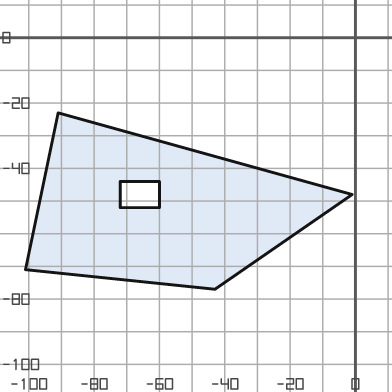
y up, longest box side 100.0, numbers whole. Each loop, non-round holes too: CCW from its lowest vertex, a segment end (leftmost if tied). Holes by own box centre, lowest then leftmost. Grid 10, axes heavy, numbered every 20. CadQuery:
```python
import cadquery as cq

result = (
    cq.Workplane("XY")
    .moveTo(-43.0, -77.0)
    .lineTo(-1.0, -48.0)
    .lineTo(-91.0, -23.0)
    .lineTo(-101.0, -71.0)
    .close()
    .moveTo(-72.0, -52.0)
    .lineTo(-60.0, -52.0)
    .lineTo(-60.0, -44.0)
    .lineTo(-72.0, -44.0)
    .close()
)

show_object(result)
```